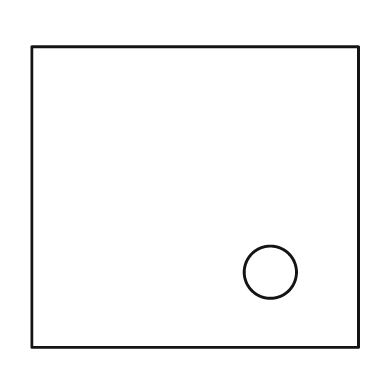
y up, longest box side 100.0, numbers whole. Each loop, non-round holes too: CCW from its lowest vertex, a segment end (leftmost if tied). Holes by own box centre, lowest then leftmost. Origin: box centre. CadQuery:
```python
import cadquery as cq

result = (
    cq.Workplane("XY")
    .moveTo(-50.0, -46.0)
    .lineTo(50.0, -46.0)
    .lineTo(50.0, 46.0)
    .lineTo(-50.0, 46.0)
    .close()
    .moveTo(23.0, -23.0)
    .circle(8.0)
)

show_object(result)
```